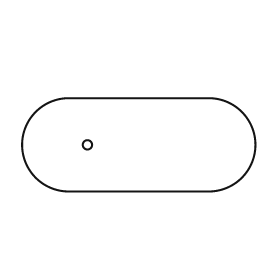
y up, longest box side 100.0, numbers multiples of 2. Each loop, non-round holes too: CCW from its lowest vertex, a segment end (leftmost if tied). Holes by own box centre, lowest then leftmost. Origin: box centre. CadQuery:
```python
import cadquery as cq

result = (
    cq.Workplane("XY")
    .moveTo(-30.0, -20.0)
    .lineTo(30.0, -20.0)
    .threePointArc((50.0, 0.0), (30.0, 20.0))
    .lineTo(-30.0, 20.0)
    .threePointArc((-50.0, 0.0), (-30.0, -20.0))
    .close()
    .moveTo(-22.0, 0.0)
    .circle(2.0)
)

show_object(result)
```